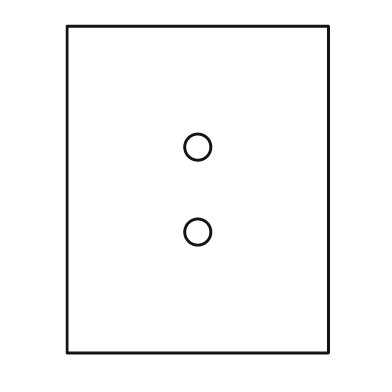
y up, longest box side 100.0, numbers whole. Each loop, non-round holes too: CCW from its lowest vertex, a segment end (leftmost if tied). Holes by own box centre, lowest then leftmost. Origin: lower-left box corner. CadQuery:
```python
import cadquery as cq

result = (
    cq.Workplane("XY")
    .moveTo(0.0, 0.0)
    .lineTo(80.0, 0.0)
    .lineTo(80.0, 100.0)
    .lineTo(0.0, 100.0)
    .close()
    .moveTo(40.0, 37.0)
    .circle(4.0)
    .moveTo(40.0, 63.0)
    .circle(4.0)
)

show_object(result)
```